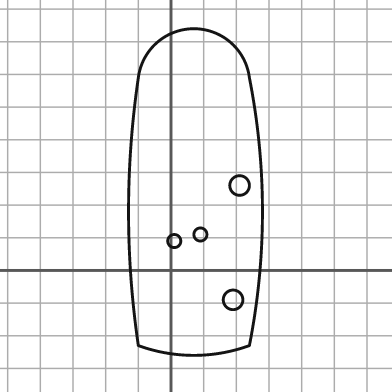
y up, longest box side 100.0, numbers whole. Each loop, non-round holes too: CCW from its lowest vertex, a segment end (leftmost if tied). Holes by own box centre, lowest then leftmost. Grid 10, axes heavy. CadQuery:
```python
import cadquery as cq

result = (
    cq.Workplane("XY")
    .moveTo(-10.0, -23.0)
    .threePointArc((7.0, -26.0), (24.0, -23.0))
    .threePointArc((28.0, 18.0), (24.0, 59.0))
    .threePointArc((7.0, 74.0), (-10.0, 59.0))
    .threePointArc((-13.0, 18.0), (-10.0, -23.0))
    .close()
    .moveTo(19.0, -9.0)
    .circle(3.0)
    .moveTo(1.0, 9.0)
    .circle(2.0)
    .moveTo(9.0, 11.0)
    .circle(2.0)
    .moveTo(21.0, 26.0)
    .circle(3.0)
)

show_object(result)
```